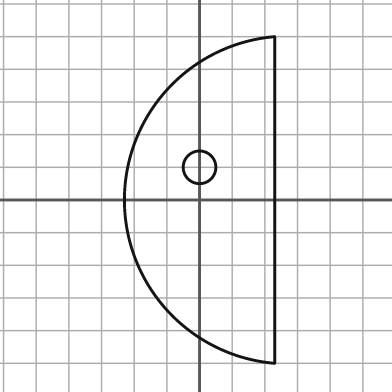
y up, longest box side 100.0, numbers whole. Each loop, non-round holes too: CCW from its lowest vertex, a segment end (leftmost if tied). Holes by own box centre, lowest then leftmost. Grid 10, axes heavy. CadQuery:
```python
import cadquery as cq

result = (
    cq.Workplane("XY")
    .moveTo(23.0, -50.0)
    .lineTo(23.0, 50.0)
    .threePointArc((-23.0, 0.0), (23.0, -50.0))
    .close()
    .moveTo(0.0, 10.0)
    .circle(5.0)
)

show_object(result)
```